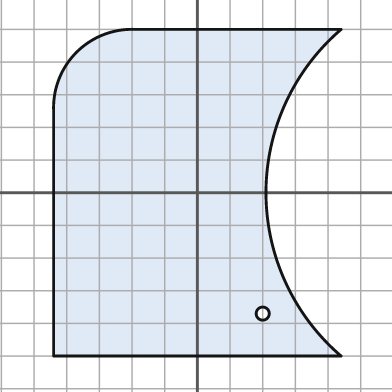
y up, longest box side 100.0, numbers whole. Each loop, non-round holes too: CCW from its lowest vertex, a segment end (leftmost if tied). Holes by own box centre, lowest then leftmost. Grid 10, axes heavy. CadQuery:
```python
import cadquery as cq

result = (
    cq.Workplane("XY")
    .moveTo(-44.0, -50.0)
    .lineTo(44.0, -50.0)
    .threePointArc((21.0, 0.0), (44.0, 50.0))
    .lineTo(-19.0, 50.0)
    .threePointArc((-37.0, 43.0), (-44.0, 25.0))
    .close()
    .moveTo(20.0, -37.0)
    .circle(2.0)
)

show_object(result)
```